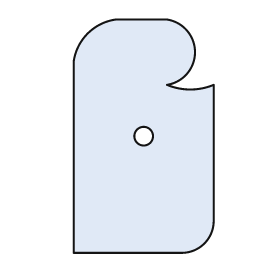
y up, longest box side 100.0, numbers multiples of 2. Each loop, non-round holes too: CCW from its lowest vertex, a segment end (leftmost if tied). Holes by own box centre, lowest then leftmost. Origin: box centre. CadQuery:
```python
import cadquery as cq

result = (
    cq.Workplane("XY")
    .moveTo(-30.0, -50.0)
    .lineTo(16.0, -50.0)
    .threePointArc((26.0, -46.0), (30.0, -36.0))
    .lineTo(30.0, 22.0)
    .threePointArc((20.0, 20.0), (10.0, 22.0))
    .threePointArc((22.0, 36.0), (10.0, 50.0))
    .lineTo(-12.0, 50.0)
    .threePointArc((-24.0, 44.0), (-30.0, 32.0))
    .close()
    .moveTo(0.0, 0.0)
    .circle(4.0)
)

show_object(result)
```